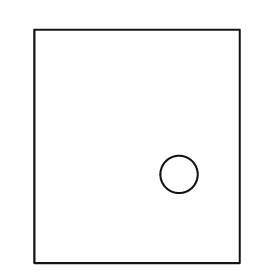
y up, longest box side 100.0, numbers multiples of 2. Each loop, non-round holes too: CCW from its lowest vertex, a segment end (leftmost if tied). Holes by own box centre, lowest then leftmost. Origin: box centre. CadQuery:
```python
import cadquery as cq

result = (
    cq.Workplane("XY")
    .moveTo(-44.0, -50.0)
    .lineTo(44.0, -50.0)
    .lineTo(44.0, 50.0)
    .lineTo(-44.0, 50.0)
    .close()
    .moveTo(18.0, -12.0)
    .circle(8.0)
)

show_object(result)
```